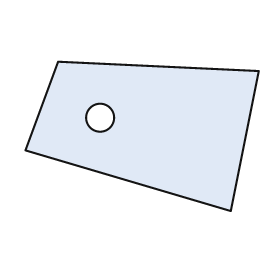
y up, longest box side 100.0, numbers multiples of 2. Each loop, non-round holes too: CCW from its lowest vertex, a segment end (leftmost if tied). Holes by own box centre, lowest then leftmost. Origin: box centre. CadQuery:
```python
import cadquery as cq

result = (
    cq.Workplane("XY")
    .moveTo(38.0, -32.0)
    .lineTo(50.0, 28.0)
    .lineTo(-36.0, 32.0)
    .lineTo(-50.0, -6.0)
    .close()
    .moveTo(-18.0, 8.0)
    .circle(6.0)
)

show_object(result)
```